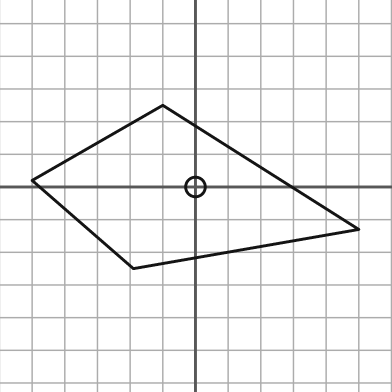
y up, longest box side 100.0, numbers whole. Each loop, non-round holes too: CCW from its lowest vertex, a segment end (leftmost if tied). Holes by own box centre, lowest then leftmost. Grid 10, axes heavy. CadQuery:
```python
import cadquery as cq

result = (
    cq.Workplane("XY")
    .moveTo(-19.0, -25.0)
    .lineTo(50.0, -13.0)
    .lineTo(-10.0, 25.0)
    .lineTo(-50.0, 2.0)
    .close()
    .moveTo(0.0, 0.0)
    .circle(3.0)
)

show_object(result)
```